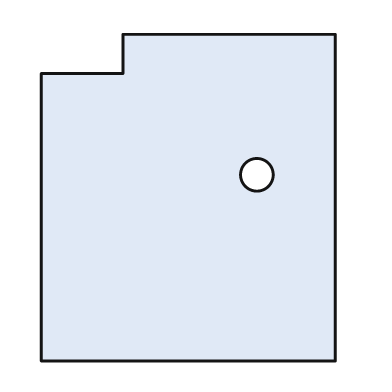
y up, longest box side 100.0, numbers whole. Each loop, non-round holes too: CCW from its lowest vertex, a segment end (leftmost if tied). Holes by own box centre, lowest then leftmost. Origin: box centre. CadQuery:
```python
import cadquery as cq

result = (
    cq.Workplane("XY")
    .moveTo(-45.0, -50.0)
    .lineTo(45.0, -50.0)
    .lineTo(45.0, 50.0)
    .lineTo(-20.0, 50.0)
    .lineTo(-20.0, 38.0)
    .lineTo(-45.0, 38.0)
    .close()
    .moveTo(21.0, 7.0)
    .circle(5.0)
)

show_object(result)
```